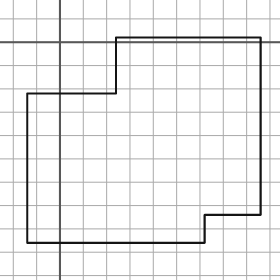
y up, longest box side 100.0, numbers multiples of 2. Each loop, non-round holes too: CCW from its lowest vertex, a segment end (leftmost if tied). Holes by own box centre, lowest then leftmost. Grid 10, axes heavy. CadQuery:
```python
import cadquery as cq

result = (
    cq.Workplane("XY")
    .moveTo(-14.0, -86.0)
    .lineTo(62.0, -86.0)
    .lineTo(62.0, -74.0)
    .lineTo(86.0, -74.0)
    .lineTo(86.0, 2.0)
    .lineTo(24.0, 2.0)
    .lineTo(24.0, -22.0)
    .lineTo(-14.0, -22.0)
    .close()
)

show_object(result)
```